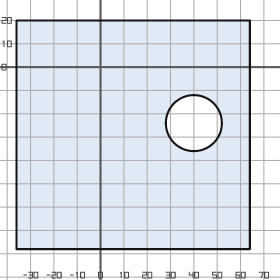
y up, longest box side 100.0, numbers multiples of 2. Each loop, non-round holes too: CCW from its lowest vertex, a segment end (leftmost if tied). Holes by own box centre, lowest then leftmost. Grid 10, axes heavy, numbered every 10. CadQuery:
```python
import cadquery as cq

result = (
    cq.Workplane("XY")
    .moveTo(-36.0, -78.0)
    .lineTo(64.0, -78.0)
    .lineTo(64.0, 20.0)
    .lineTo(-36.0, 20.0)
    .close()
    .moveTo(40.0, -24.0)
    .circle(12.0)
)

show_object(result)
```